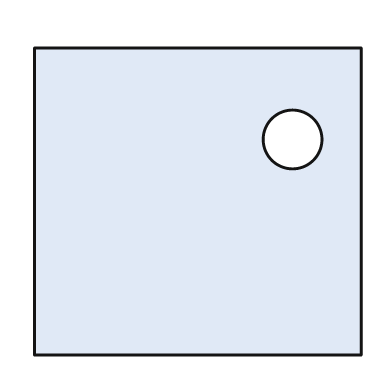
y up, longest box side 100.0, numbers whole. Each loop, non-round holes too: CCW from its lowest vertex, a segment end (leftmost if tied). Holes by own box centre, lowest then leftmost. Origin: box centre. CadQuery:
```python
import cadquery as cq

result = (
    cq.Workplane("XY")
    .moveTo(-50.0, -47.0)
    .lineTo(50.0, -47.0)
    .lineTo(50.0, 47.0)
    .lineTo(-50.0, 47.0)
    .close()
    .moveTo(29.0, 19.0)
    .circle(9.0)
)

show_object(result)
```